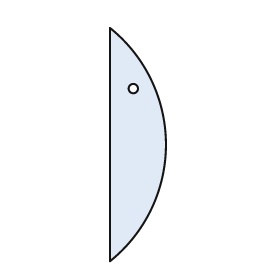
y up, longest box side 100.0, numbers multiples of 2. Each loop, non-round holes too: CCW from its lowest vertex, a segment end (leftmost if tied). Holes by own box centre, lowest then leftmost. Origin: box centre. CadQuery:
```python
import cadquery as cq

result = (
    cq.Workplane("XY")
    .moveTo(-12.0, -50.0)
    .threePointArc((12.0, 0.0), (-12.0, 50.0))
    .close()
    .moveTo(-2.0, 24.0)
    .circle(2.0)
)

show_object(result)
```